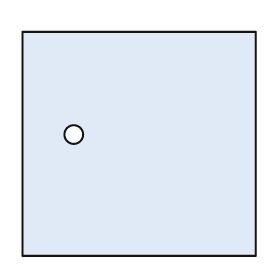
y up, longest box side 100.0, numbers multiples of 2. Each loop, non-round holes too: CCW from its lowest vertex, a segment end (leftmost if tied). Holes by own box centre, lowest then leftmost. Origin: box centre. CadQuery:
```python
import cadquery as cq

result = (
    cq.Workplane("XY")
    .moveTo(-50.0, -48.0)
    .lineTo(50.0, -48.0)
    .lineTo(50.0, 48.0)
    .lineTo(-50.0, 48.0)
    .close()
    .moveTo(-28.0, 4.0)
    .circle(4.0)
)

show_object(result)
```